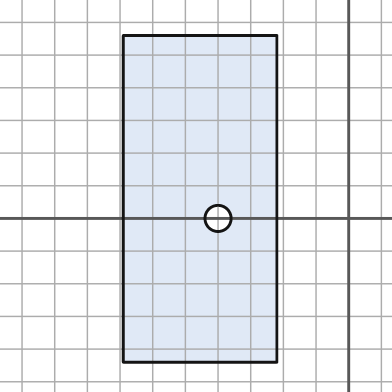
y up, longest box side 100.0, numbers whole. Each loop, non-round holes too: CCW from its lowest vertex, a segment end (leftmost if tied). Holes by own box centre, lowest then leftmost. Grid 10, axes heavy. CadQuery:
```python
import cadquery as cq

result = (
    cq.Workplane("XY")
    .moveTo(-69.0, -44.0)
    .lineTo(-22.0, -44.0)
    .lineTo(-22.0, 56.0)
    .lineTo(-69.0, 56.0)
    .close()
    .moveTo(-40.0, 0.0)
    .circle(4.0)
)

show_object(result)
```